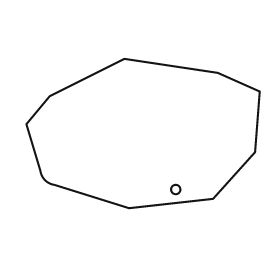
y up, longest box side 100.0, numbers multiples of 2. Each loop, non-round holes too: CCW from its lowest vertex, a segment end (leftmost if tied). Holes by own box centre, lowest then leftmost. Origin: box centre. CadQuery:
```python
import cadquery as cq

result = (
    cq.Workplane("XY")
    .moveTo(-6.0, -32.0)
    .lineTo(30.0, -28.0)
    .lineTo(48.0, -8.0)
    .lineTo(50.0, 18.0)
    .lineTo(32.0, 26.0)
    .lineTo(-8.0, 32.0)
    .lineTo(-40.0, 16.0)
    .lineTo(-50.0, 4.0)
    .lineTo(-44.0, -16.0)
    .threePointArc((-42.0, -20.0), (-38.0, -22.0))
    .close()
    .moveTo(14.0, -24.0)
    .circle(2.0)
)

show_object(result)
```